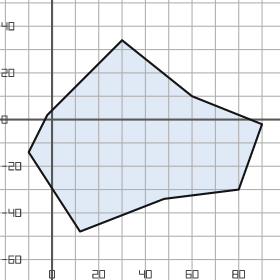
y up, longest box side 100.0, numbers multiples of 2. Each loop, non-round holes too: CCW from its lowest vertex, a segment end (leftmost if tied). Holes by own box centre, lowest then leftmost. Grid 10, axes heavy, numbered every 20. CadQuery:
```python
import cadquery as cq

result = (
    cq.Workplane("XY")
    .moveTo(12.0, -48.0)
    .lineTo(48.0, -34.0)
    .lineTo(80.0, -30.0)
    .lineTo(90.0, -2.0)
    .lineTo(60.0, 10.0)
    .lineTo(30.0, 34.0)
    .lineTo(-2.0, 2.0)
    .lineTo(-10.0, -14.0)
    .close()
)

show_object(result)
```